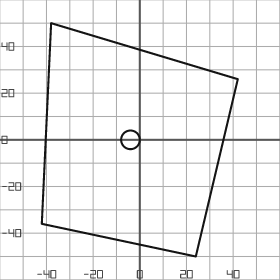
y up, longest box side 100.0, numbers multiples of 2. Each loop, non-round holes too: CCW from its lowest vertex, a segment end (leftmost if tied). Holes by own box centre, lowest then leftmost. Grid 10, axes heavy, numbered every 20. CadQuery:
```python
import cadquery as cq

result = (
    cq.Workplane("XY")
    .moveTo(24.0, -50.0)
    .lineTo(42.0, 26.0)
    .lineTo(-38.0, 50.0)
    .lineTo(-42.0, -36.0)
    .close()
    .moveTo(-4.0, 0.0)
    .circle(4.0)
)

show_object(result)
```